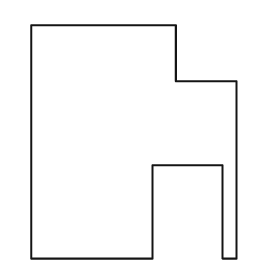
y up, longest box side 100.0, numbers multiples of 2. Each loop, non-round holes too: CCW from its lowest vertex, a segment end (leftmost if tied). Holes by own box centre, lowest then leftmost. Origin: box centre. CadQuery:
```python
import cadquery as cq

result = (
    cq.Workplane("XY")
    .moveTo(-44.0, -50.0)
    .lineTo(8.0, -50.0)
    .lineTo(8.0, -10.0)
    .lineTo(38.0, -10.0)
    .lineTo(38.0, -50.0)
    .lineTo(44.0, -50.0)
    .lineTo(44.0, 26.0)
    .lineTo(18.0, 26.0)
    .lineTo(18.0, 50.0)
    .lineTo(-44.0, 50.0)
    .close()
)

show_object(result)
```